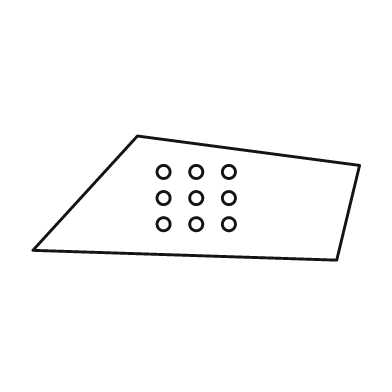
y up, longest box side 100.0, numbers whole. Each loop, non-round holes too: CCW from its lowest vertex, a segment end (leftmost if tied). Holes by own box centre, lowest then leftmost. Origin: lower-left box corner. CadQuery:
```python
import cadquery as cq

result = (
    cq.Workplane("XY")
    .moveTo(93.0, 0.0)
    .lineTo(100.0, 29.0)
    .lineTo(32.0, 38.0)
    .lineTo(0.0, 3.0)
    .close()
    .moveTo(40.0, 11.0)
    .circle(2.0)
    .moveTo(50.0, 11.0)
    .circle(2.0)
    .moveTo(60.0, 11.0)
    .circle(2.0)
    .moveTo(40.0, 19.0)
    .circle(2.0)
    .moveTo(50.0, 19.0)
    .circle(2.0)
    .moveTo(60.0, 19.0)
    .circle(2.0)
    .moveTo(40.0, 27.0)
    .circle(2.0)
    .moveTo(50.0, 27.0)
    .circle(2.0)
    .moveTo(60.0, 27.0)
    .circle(2.0)
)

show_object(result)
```